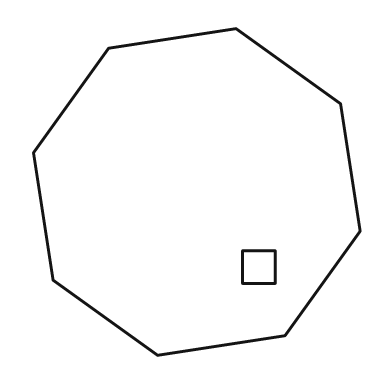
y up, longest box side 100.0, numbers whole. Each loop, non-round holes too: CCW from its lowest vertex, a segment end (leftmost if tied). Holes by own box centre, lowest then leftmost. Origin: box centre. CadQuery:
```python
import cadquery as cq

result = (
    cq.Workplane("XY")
    .moveTo(-12.0, -50.0)
    .lineTo(27.0, -44.0)
    .lineTo(50.0, -12.0)
    .lineTo(44.0, 27.0)
    .lineTo(12.0, 50.0)
    .lineTo(-27.0, 44.0)
    .lineTo(-50.0, 12.0)
    .lineTo(-44.0, -27.0)
    .close()
    .moveTo(14.0, -28.0)
    .lineTo(24.0, -28.0)
    .lineTo(24.0, -18.0)
    .lineTo(14.0, -18.0)
    .close()
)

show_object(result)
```